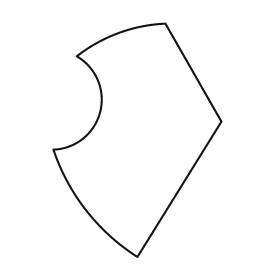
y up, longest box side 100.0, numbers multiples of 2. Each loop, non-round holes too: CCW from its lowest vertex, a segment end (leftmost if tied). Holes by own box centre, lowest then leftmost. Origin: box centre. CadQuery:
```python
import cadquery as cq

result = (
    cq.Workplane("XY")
    .moveTo(0.0, -50.0)
    .lineTo(36.0, 8.0)
    .lineTo(12.0, 50.0)
    .threePointArc((-8.0, 46.0), (-26.0, 36.0))
    .threePointArc((-16.0, 12.0), (-36.0, -4.0))
    .threePointArc((-22.0, -30.0), (0.0, -50.0))
    .close()
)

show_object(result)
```